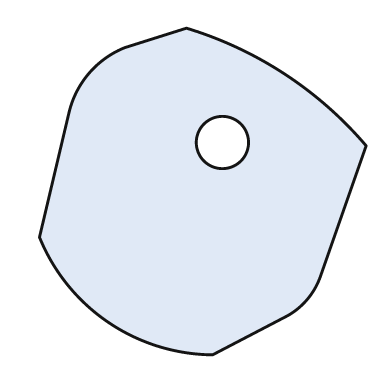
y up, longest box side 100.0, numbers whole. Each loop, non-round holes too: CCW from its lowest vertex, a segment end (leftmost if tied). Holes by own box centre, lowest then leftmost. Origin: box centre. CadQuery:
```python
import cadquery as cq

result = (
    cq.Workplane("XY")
    .moveTo(3.0, -50.0)
    .lineTo(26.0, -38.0)
    .threePointArc((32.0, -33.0), (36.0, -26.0))
    .lineTo(50.0, 14.0)
    .threePointArc((25.0, 36.0), (-5.0, 50.0))
    .lineTo(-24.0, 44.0)
    .threePointArc((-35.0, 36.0), (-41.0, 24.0))
    .lineTo(-50.0, -14.0)
    .threePointArc((-29.0, -40.0), (3.0, -50.0))
    .close()
    .moveTo(6.0, 15.0)
    .circle(8.0)
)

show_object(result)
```